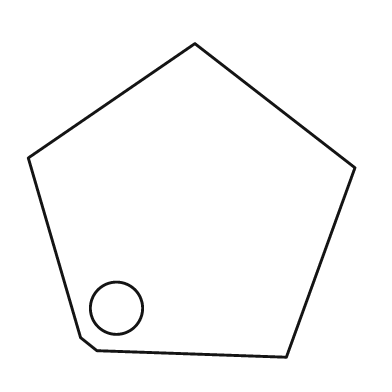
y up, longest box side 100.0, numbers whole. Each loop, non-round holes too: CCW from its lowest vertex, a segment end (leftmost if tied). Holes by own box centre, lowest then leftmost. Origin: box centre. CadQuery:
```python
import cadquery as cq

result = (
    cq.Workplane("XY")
    .moveTo(29.0, -48.0)
    .lineTo(50.0, 10.0)
    .lineTo(1.0, 48.0)
    .lineTo(-50.0, 13.0)
    .lineTo(-34.0, -42.0)
    .lineTo(-29.0, -46.0)
    .close()
    .moveTo(-23.0, -33.0)
    .circle(8.0)
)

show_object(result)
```